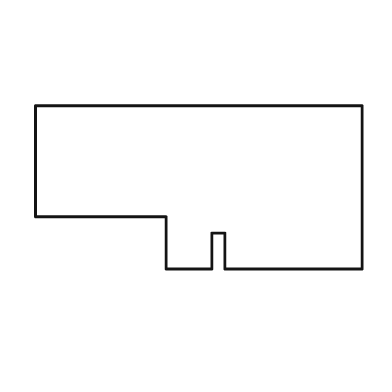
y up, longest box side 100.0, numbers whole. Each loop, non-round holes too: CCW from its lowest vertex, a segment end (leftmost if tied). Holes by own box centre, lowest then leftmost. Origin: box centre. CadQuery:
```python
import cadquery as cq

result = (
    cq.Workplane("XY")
    .moveTo(-10.0, -25.0)
    .lineTo(4.0, -25.0)
    .lineTo(4.0, -14.0)
    .lineTo(8.0, -14.0)
    .lineTo(8.0, -25.0)
    .lineTo(50.0, -25.0)
    .lineTo(50.0, 25.0)
    .lineTo(-50.0, 25.0)
    .lineTo(-50.0, -9.0)
    .lineTo(-10.0, -9.0)
    .close()
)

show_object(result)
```